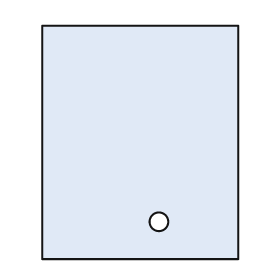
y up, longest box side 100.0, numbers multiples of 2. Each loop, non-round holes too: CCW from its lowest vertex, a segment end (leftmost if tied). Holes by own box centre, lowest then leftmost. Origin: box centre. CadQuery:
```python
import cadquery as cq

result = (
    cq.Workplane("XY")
    .moveTo(-42.0, -50.0)
    .lineTo(42.0, -50.0)
    .lineTo(42.0, 50.0)
    .lineTo(-42.0, 50.0)
    .close()
    .moveTo(8.0, -34.0)
    .circle(4.0)
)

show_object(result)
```